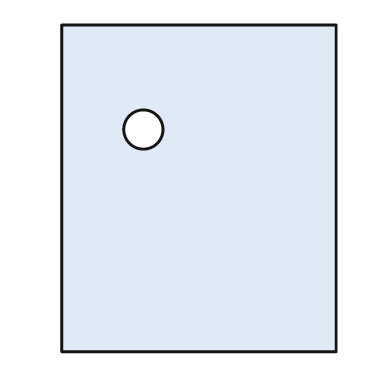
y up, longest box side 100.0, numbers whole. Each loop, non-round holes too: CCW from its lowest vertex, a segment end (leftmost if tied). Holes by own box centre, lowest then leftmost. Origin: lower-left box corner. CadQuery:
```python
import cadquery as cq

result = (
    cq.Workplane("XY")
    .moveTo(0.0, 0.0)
    .lineTo(84.0, 0.0)
    .lineTo(84.0, 100.0)
    .lineTo(0.0, 100.0)
    .close()
    .moveTo(25.0, 68.0)
    .circle(6.0)
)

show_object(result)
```